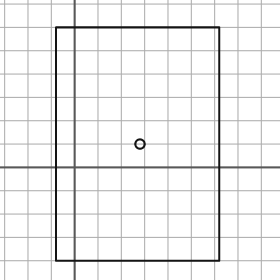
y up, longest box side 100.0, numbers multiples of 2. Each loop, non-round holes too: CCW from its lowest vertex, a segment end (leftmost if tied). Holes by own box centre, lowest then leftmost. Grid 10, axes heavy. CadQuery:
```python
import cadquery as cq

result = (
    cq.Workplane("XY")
    .moveTo(-8.0, -40.0)
    .lineTo(62.0, -40.0)
    .lineTo(62.0, 60.0)
    .lineTo(-8.0, 60.0)
    .close()
    .moveTo(28.0, 10.0)
    .circle(2.0)
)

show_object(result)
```